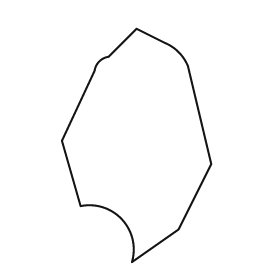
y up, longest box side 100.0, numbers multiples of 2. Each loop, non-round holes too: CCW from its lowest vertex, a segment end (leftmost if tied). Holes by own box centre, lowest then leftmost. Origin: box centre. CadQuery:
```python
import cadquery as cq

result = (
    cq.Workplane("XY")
    .moveTo(-2.0, -50.0)
    .lineTo(18.0, -36.0)
    .lineTo(32.0, -8.0)
    .lineTo(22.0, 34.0)
    .threePointArc((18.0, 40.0), (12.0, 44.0))
    .lineTo(0.0, 50.0)
    .lineTo(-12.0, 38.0)
    .threePointArc((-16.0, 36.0), (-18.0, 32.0))
    .lineTo(-32.0, 2.0)
    .lineTo(-24.0, -26.0)
    .threePointArc((-6.0, -32.0), (-2.0, -50.0))
    .close()
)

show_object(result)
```